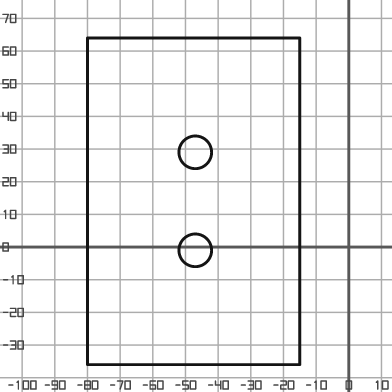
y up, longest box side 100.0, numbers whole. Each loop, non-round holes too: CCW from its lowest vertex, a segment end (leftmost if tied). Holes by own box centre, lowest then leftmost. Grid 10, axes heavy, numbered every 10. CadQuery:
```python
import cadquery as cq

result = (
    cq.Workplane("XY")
    .moveTo(-80.0, -36.0)
    .lineTo(-15.0, -36.0)
    .lineTo(-15.0, 64.0)
    .lineTo(-80.0, 64.0)
    .close()
    .moveTo(-47.0, -1.0)
    .circle(5.0)
    .moveTo(-47.0, 29.0)
    .circle(5.0)
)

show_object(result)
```